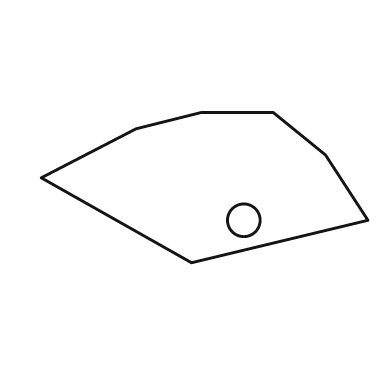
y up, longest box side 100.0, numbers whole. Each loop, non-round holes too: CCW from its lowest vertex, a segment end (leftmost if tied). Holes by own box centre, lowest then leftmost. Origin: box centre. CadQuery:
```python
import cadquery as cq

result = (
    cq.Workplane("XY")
    .moveTo(-4.0, -23.0)
    .lineTo(50.0, -10.0)
    .lineTo(37.0, 10.0)
    .lineTo(21.0, 23.0)
    .lineTo(-1.0, 23.0)
    .lineTo(-21.0, 18.0)
    .lineTo(-50.0, 3.0)
    .close()
    .moveTo(12.0, -10.0)
    .circle(5.0)
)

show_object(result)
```